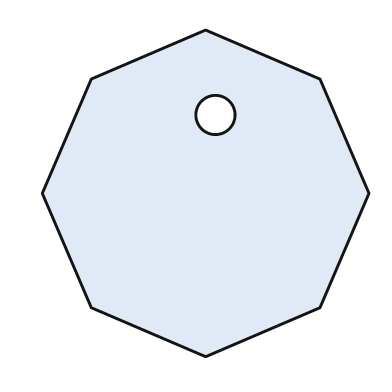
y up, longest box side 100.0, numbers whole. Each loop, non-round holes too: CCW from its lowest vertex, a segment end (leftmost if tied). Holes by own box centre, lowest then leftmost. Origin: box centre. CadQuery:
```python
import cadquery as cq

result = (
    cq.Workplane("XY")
    .moveTo(0.0, -50.0)
    .lineTo(35.0, -35.0)
    .lineTo(50.0, 0.0)
    .lineTo(35.0, 35.0)
    .lineTo(0.0, 50.0)
    .lineTo(-35.0, 35.0)
    .lineTo(-50.0, 0.0)
    .lineTo(-35.0, -35.0)
    .close()
    .moveTo(3.0, 24.0)
    .circle(6.0)
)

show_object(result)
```